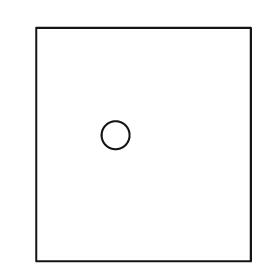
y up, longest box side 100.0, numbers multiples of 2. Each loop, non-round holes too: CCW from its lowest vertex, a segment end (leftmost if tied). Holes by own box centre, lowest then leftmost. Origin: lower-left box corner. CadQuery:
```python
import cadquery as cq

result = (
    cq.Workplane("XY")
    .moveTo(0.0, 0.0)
    .lineTo(92.0, 0.0)
    .lineTo(92.0, 100.0)
    .lineTo(0.0, 100.0)
    .close()
    .moveTo(34.0, 54.0)
    .circle(6.0)
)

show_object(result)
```